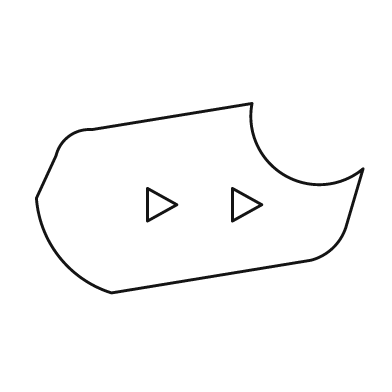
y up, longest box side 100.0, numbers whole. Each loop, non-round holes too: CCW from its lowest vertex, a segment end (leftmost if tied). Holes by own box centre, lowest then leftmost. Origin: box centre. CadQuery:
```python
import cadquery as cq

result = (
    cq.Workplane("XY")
    .moveTo(-27.0, -29.0)
    .lineTo(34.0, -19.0)
    .threePointArc((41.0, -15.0), (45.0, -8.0))
    .lineTo(50.0, 9.0)
    .threePointArc((26.0, 7.0), (16.0, 29.0))
    .lineTo(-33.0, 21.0)
    .threePointArc((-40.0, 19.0), (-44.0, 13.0))
    .lineTo(-50.0, 0.0)
    .threePointArc((-43.0, -18.0), (-27.0, -29.0))
    .close()
    .moveTo(-16.0, -7.0)
    .lineTo(-7.0, -2.0)
    .lineTo(-16.0, 3.0)
    .close()
    .moveTo(10.0, -7.0)
    .lineTo(19.0, -2.0)
    .lineTo(10.0, 3.0)
    .close()
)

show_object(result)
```